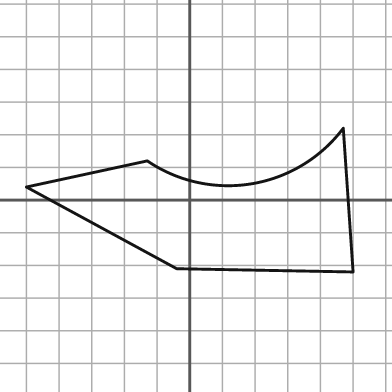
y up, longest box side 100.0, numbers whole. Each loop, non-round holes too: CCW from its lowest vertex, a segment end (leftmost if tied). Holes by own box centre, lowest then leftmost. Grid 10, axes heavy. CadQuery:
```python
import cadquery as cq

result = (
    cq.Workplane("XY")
    .moveTo(50.0, -22.0)
    .lineTo(47.0, 22.0)
    .threePointArc((19.0, 5.0), (-13.0, 12.0))
    .lineTo(-50.0, 4.0)
    .lineTo(-4.0, -21.0)
    .close()
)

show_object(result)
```